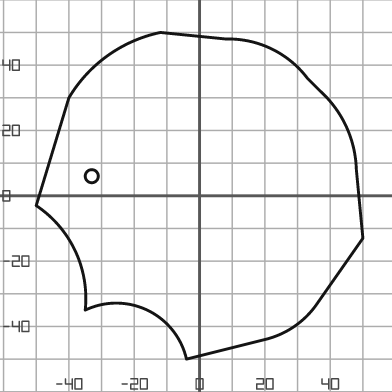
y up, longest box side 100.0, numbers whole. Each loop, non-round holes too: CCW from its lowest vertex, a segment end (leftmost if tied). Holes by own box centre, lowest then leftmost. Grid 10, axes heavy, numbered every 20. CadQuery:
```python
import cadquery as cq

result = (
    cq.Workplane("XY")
    .moveTo(-4.0, -50.0)
    .lineTo(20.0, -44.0)
    .threePointArc((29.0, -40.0), (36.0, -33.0))
    .lineTo(50.0, -13.0)
    .lineTo(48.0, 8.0)
    .threePointArc((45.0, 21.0), (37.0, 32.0))
    .lineTo(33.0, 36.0)
    .threePointArc((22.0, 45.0), (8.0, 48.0))
    .lineTo(-12.0, 50.0)
    .threePointArc((-28.0, 43.0), (-40.0, 30.0))
    .lineTo(-50.0, -3.0)
    .threePointArc((-38.0, -17.0), (-35.0, -35.0))
    .threePointArc((-16.0, -35.0), (-4.0, -50.0))
    .close()
    .moveTo(-33.0, 6.0)
    .circle(2.0)
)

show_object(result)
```